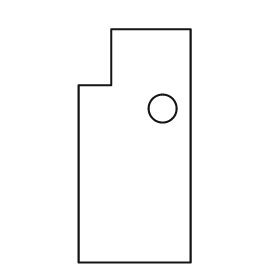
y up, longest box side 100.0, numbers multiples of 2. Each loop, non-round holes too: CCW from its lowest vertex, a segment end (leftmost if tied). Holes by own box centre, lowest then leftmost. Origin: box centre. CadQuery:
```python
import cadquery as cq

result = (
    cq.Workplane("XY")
    .moveTo(-24.0, -50.0)
    .lineTo(24.0, -50.0)
    .lineTo(24.0, 50.0)
    .lineTo(-10.0, 50.0)
    .lineTo(-10.0, 26.0)
    .lineTo(-24.0, 26.0)
    .close()
    .moveTo(12.0, 16.0)
    .circle(6.0)
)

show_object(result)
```